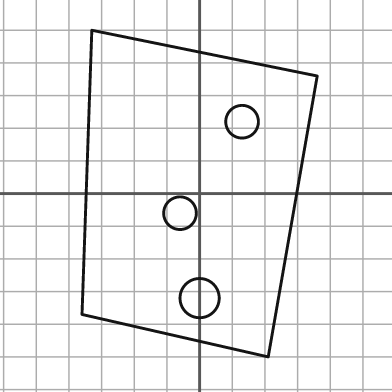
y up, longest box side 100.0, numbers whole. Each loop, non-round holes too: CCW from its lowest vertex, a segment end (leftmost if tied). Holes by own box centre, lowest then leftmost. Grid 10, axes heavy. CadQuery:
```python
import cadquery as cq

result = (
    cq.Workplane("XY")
    .moveTo(21.0, -50.0)
    .lineTo(36.0, 36.0)
    .lineTo(-33.0, 50.0)
    .lineTo(-36.0, -37.0)
    .close()
    .moveTo(0.0, -32.0)
    .circle(6.0)
    .moveTo(-6.0, -6.0)
    .circle(5.0)
    .moveTo(13.0, 22.0)
    .circle(5.0)
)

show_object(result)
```